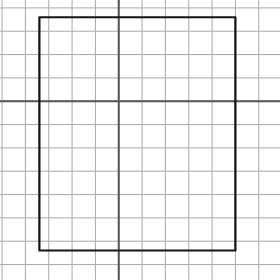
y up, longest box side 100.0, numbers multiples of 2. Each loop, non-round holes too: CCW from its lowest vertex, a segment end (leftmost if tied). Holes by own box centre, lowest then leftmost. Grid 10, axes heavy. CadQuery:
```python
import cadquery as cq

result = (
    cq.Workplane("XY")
    .moveTo(-34.0, -64.0)
    .lineTo(50.0, -64.0)
    .lineTo(50.0, 36.0)
    .lineTo(-34.0, 36.0)
    .close()
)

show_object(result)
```